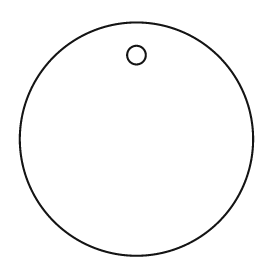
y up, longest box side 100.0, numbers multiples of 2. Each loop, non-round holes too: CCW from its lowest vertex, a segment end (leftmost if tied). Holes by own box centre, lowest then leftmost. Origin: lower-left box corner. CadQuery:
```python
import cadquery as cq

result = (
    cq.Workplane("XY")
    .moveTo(50.0, 50.0)
    .circle(50.0)
    .moveTo(50.0, 86.0)
    .circle(4.0)
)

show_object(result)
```